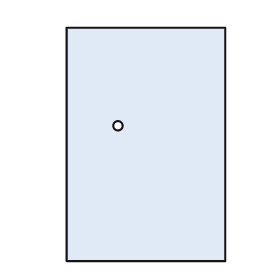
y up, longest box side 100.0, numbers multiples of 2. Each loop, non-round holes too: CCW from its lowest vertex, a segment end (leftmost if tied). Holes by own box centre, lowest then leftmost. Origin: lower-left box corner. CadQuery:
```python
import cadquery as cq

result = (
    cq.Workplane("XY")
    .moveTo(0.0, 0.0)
    .lineTo(68.0, 0.0)
    .lineTo(68.0, 100.0)
    .lineTo(0.0, 100.0)
    .close()
    .moveTo(22.0, 58.0)
    .circle(2.0)
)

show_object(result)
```